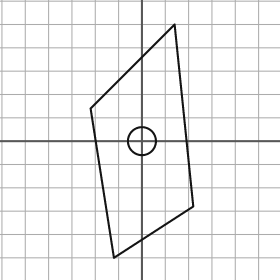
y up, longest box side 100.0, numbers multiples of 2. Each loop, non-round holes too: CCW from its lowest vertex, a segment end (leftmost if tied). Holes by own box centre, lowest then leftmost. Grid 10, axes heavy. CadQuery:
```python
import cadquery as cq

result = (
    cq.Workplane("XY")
    .moveTo(-12.0, -50.0)
    .lineTo(22.0, -28.0)
    .lineTo(14.0, 50.0)
    .lineTo(-22.0, 14.0)
    .close()
    .moveTo(0.0, 0.0)
    .circle(6.0)
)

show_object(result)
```